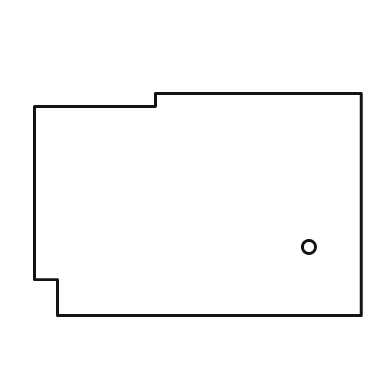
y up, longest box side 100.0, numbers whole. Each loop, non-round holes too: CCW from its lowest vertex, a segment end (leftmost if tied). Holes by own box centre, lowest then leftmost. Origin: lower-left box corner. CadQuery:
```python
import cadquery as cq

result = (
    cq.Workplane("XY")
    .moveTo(7.0, 0.0)
    .lineTo(100.0, 0.0)
    .lineTo(100.0, 68.0)
    .lineTo(37.0, 68.0)
    .lineTo(37.0, 64.0)
    .lineTo(0.0, 64.0)
    .lineTo(0.0, 11.0)
    .lineTo(7.0, 11.0)
    .close()
    .moveTo(84.0, 21.0)
    .circle(2.0)
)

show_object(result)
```